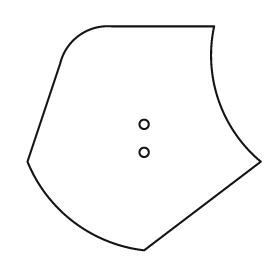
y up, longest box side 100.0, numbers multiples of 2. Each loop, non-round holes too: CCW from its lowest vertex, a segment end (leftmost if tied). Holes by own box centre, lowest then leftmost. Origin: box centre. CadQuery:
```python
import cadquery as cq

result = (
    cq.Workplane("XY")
    .moveTo(0.0, -48.0)
    .lineTo(50.0, -10.0)
    .threePointArc((32.0, 16.0), (30.0, 48.0))
    .lineTo(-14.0, 48.0)
    .threePointArc((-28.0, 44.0), (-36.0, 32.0))
    .lineTo(-50.0, -10.0)
    .threePointArc((-30.0, -36.0), (0.0, -48.0))
    .close()
    .moveTo(0.0, -6.0)
    .circle(2.0)
    .moveTo(0.0, 6.0)
    .circle(2.0)
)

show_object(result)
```